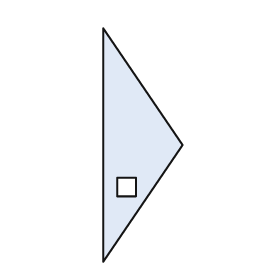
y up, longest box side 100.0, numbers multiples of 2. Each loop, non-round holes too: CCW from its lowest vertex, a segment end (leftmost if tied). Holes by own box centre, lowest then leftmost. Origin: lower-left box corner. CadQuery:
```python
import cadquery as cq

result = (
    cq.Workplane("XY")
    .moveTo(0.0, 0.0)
    .lineTo(34.0, 50.0)
    .lineTo(0.0, 100.0)
    .close()
    .moveTo(6.0, 28.0)
    .lineTo(14.0, 28.0)
    .lineTo(14.0, 36.0)
    .lineTo(6.0, 36.0)
    .close()
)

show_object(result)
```